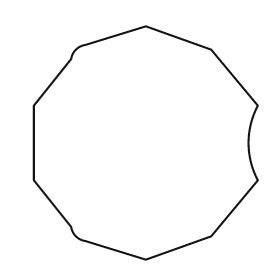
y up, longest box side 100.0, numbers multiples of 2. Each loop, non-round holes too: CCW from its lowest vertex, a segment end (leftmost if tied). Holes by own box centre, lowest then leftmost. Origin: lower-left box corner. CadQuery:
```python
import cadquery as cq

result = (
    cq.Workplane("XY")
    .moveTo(48.0, 0.0)
    .lineTo(76.0, 10.0)
    .lineTo(96.0, 34.0)
    .threePointArc((92.0, 50.0), (96.0, 66.0))
    .lineTo(76.0, 90.0)
    .lineTo(48.0, 100.0)
    .lineTo(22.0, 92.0)
    .threePointArc((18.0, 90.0), (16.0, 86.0))
    .lineTo(0.0, 66.0)
    .lineTo(0.0, 34.0)
    .lineTo(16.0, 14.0)
    .threePointArc((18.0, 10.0), (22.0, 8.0))
    .close()
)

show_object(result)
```